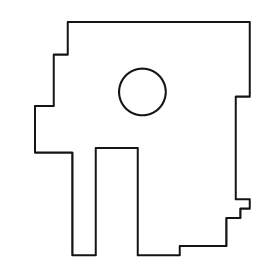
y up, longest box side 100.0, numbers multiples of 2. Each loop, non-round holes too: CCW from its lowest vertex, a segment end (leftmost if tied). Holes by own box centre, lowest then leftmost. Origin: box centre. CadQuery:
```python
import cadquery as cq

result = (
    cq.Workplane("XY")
    .moveTo(-30.0, -50.0)
    .lineTo(-20.0, -50.0)
    .lineTo(-20.0, -4.0)
    .lineTo(-2.0, -4.0)
    .lineTo(-2.0, -50.0)
    .lineTo(16.0, -50.0)
    .lineTo(16.0, -46.0)
    .lineTo(36.0, -46.0)
    .lineTo(36.0, -34.0)
    .lineTo(42.0, -34.0)
    .lineTo(42.0, -30.0)
    .lineTo(46.0, -30.0)
    .lineTo(46.0, -26.0)
    .lineTo(40.0, -26.0)
    .lineTo(40.0, 18.0)
    .lineTo(46.0, 18.0)
    .lineTo(46.0, 50.0)
    .lineTo(-32.0, 50.0)
    .lineTo(-32.0, 36.0)
    .lineTo(-38.0, 36.0)
    .lineTo(-38.0, 14.0)
    .lineTo(-46.0, 14.0)
    .lineTo(-46.0, -6.0)
    .lineTo(-30.0, -6.0)
    .close()
    .moveTo(0.0, 20.0)
    .circle(10.0)
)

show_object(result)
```